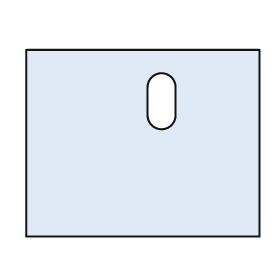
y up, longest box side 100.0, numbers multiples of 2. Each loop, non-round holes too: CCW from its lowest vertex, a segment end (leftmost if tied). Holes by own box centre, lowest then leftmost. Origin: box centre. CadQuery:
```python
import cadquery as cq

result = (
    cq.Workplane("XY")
    .moveTo(-50.0, -40.0)
    .lineTo(50.0, -40.0)
    .lineTo(50.0, 40.0)
    .lineTo(-50.0, 40.0)
    .close()
    .moveTo(2.0, 12.0)
    .threePointArc((8.0, 6.0), (14.0, 12.0))
    .lineTo(14.0, 24.0)
    .threePointArc((8.0, 30.0), (2.0, 24.0))
    .close()
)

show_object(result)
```